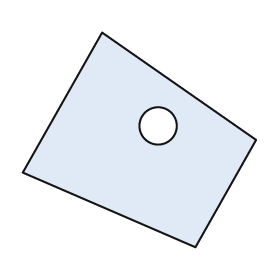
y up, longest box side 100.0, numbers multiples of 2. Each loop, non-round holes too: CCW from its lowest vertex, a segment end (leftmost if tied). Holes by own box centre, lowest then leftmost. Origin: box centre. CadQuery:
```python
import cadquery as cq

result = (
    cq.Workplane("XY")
    .moveTo(24.0, -46.0)
    .lineTo(50.0, 0.0)
    .lineTo(-16.0, 46.0)
    .lineTo(-50.0, -14.0)
    .close()
    .moveTo(8.0, 6.0)
    .circle(8.0)
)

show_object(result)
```